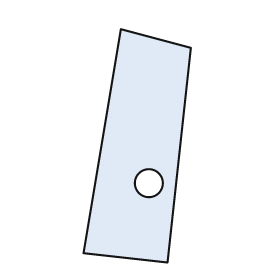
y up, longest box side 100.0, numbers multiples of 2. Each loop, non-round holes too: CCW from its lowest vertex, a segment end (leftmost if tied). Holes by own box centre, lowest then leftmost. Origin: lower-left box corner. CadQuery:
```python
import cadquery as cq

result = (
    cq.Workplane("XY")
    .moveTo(36.0, 0.0)
    .lineTo(46.0, 92.0)
    .lineTo(16.0, 100.0)
    .lineTo(0.0, 4.0)
    .close()
    .moveTo(28.0, 34.0)
    .circle(6.0)
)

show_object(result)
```